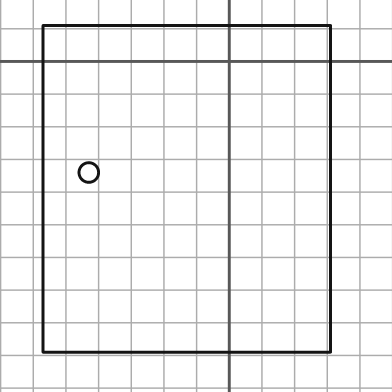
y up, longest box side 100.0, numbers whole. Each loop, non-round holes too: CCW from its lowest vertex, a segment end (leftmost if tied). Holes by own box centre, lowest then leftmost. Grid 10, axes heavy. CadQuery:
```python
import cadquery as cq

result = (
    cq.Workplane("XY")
    .moveTo(-57.0, -89.0)
    .lineTo(31.0, -89.0)
    .lineTo(31.0, 11.0)
    .lineTo(-57.0, 11.0)
    .close()
    .moveTo(-43.0, -34.0)
    .circle(3.0)
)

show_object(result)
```